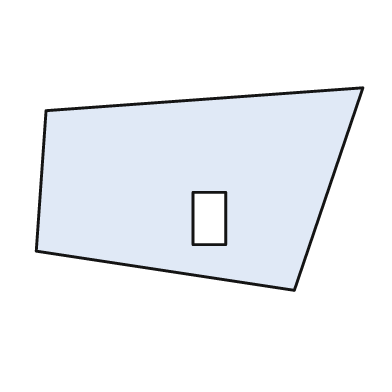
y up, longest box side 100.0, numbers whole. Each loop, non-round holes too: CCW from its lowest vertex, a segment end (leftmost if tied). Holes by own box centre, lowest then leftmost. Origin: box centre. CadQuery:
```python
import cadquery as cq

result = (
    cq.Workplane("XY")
    .moveTo(29.0, -31.0)
    .lineTo(50.0, 31.0)
    .lineTo(-47.0, 24.0)
    .lineTo(-50.0, -19.0)
    .close()
    .moveTo(-2.0, -17.0)
    .lineTo(8.0, -17.0)
    .lineTo(8.0, -1.0)
    .lineTo(-2.0, -1.0)
    .close()
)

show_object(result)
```